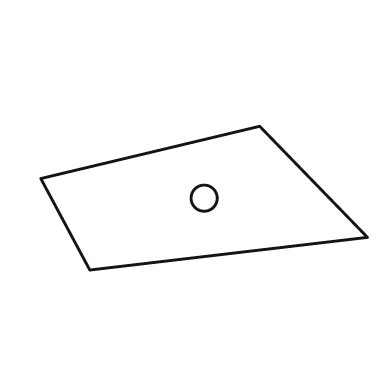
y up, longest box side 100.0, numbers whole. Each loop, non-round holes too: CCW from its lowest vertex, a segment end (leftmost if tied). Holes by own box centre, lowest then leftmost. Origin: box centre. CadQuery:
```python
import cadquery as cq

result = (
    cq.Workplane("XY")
    .moveTo(-35.0, -22.0)
    .lineTo(50.0, -12.0)
    .lineTo(17.0, 22.0)
    .lineTo(-50.0, 6.0)
    .close()
    .moveTo(0.0, 0.0)
    .circle(4.0)
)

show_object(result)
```